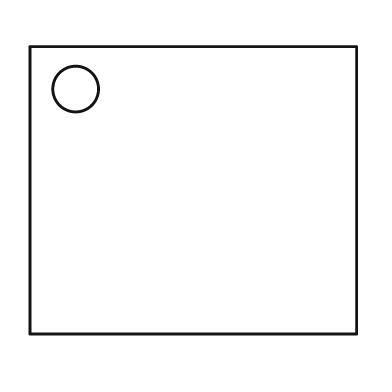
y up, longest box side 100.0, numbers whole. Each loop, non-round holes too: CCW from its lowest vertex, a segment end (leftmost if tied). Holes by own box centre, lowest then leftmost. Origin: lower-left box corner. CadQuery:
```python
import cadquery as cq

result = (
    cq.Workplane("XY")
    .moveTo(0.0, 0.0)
    .lineTo(100.0, 0.0)
    .lineTo(100.0, 88.0)
    .lineTo(0.0, 88.0)
    .close()
    .moveTo(14.0, 75.0)
    .circle(7.0)
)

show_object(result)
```